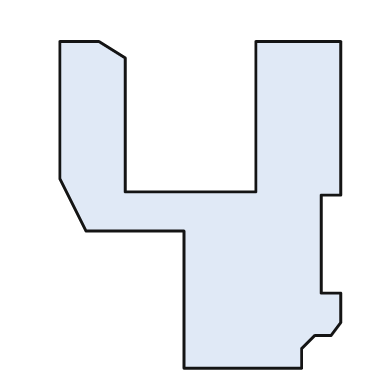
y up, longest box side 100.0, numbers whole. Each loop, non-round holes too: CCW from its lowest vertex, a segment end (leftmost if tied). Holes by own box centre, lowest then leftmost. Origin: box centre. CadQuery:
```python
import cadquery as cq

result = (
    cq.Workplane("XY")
    .moveTo(-5.0, -50.0)
    .lineTo(31.0, -50.0)
    .lineTo(31.0, -44.0)
    .lineTo(35.0, -40.0)
    .lineTo(40.0, -40.0)
    .lineTo(43.0, -36.0)
    .lineTo(43.0, -27.0)
    .lineTo(37.0, -27.0)
    .lineTo(37.0, 3.0)
    .lineTo(43.0, 3.0)
    .lineTo(43.0, 50.0)
    .lineTo(17.0, 50.0)
    .lineTo(17.0, 4.0)
    .lineTo(-23.0, 4.0)
    .lineTo(-23.0, 45.0)
    .lineTo(-31.0, 50.0)
    .lineTo(-43.0, 50.0)
    .lineTo(-43.0, 8.0)
    .lineTo(-35.0, -8.0)
    .lineTo(-5.0, -8.0)
    .close()
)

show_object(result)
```